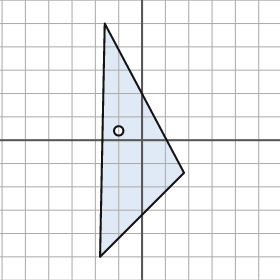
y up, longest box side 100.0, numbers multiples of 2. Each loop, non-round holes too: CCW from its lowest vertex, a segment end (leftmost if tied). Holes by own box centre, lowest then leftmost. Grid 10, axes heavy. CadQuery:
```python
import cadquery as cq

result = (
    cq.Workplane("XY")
    .moveTo(-18.0, -50.0)
    .lineTo(18.0, -14.0)
    .lineTo(-16.0, 50.0)
    .close()
    .moveTo(-10.0, 4.0)
    .circle(2.0)
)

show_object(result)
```